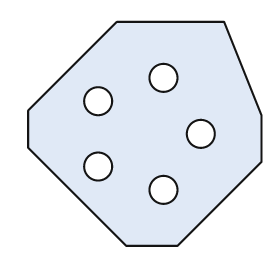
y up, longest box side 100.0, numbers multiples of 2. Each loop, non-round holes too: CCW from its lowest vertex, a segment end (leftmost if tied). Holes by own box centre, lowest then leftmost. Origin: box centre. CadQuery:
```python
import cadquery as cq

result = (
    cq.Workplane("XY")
    .moveTo(-8.0, -48.0)
    .lineTo(14.0, -48.0)
    .lineTo(50.0, -12.0)
    .lineTo(50.0, 8.0)
    .lineTo(34.0, 48.0)
    .lineTo(-12.0, 48.0)
    .lineTo(-50.0, 10.0)
    .lineTo(-50.0, -6.0)
    .close()
    .moveTo(8.0, -24.0)
    .circle(6.0)
    .moveTo(-20.0, -14.0)
    .circle(6.0)
    .moveTo(24.0, 0.0)
    .circle(6.0)
    .moveTo(-20.0, 14.0)
    .circle(6.0)
    .moveTo(8.0, 24.0)
    .circle(6.0)
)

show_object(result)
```